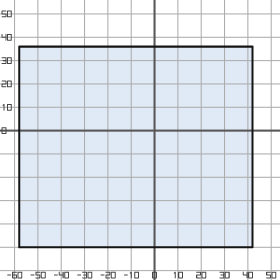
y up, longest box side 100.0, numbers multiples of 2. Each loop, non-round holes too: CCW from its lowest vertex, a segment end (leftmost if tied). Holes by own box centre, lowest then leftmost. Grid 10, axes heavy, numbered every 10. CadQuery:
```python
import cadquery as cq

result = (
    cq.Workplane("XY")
    .moveTo(-58.0, -50.0)
    .lineTo(42.0, -50.0)
    .lineTo(42.0, 36.0)
    .lineTo(-58.0, 36.0)
    .close()
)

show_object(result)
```